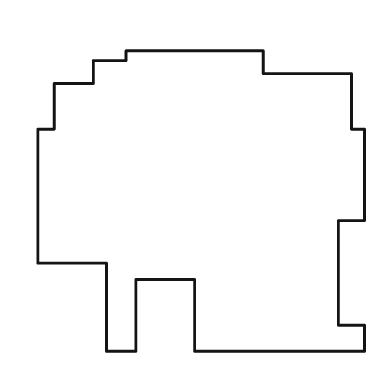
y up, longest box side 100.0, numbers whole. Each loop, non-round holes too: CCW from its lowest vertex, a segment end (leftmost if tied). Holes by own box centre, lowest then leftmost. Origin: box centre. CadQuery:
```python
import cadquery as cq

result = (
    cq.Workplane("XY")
    .moveTo(-29.0, -46.0)
    .lineTo(-20.0, -46.0)
    .lineTo(-20.0, -24.0)
    .lineTo(-2.0, -24.0)
    .lineTo(-2.0, -46.0)
    .lineTo(50.0, -46.0)
    .lineTo(50.0, -38.0)
    .lineTo(42.0, -38.0)
    .lineTo(42.0, -6.0)
    .lineTo(50.0, -6.0)
    .lineTo(50.0, 22.0)
    .lineTo(46.0, 22.0)
    .lineTo(46.0, 39.0)
    .lineTo(19.0, 39.0)
    .lineTo(19.0, 46.0)
    .lineTo(-23.0, 46.0)
    .lineTo(-23.0, 43.0)
    .lineTo(-33.0, 43.0)
    .lineTo(-33.0, 36.0)
    .lineTo(-45.0, 36.0)
    .lineTo(-45.0, 22.0)
    .lineTo(-50.0, 22.0)
    .lineTo(-50.0, -19.0)
    .lineTo(-29.0, -19.0)
    .close()
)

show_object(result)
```